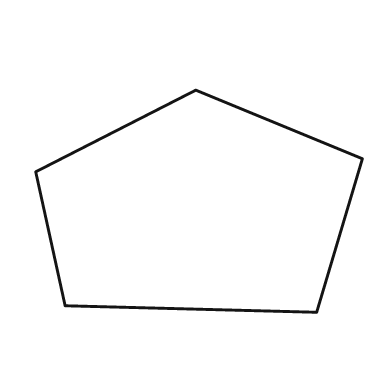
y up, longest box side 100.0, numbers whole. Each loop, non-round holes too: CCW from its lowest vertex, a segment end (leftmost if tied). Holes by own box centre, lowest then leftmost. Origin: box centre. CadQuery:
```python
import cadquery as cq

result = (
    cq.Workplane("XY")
    .moveTo(36.0, -34.0)
    .lineTo(50.0, 13.0)
    .lineTo(-1.0, 34.0)
    .lineTo(-50.0, 9.0)
    .lineTo(-41.0, -32.0)
    .close()
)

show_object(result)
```